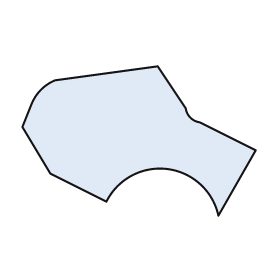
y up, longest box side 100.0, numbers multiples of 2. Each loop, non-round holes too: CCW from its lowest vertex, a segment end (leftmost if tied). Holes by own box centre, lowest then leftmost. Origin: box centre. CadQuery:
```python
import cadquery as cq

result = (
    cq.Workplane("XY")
    .moveTo(34.0, -32.0)
    .lineTo(50.0, -4.0)
    .lineTo(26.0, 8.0)
    .threePointArc((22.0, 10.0), (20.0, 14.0))
    .lineTo(8.0, 32.0)
    .lineTo(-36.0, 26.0)
    .threePointArc((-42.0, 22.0), (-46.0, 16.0))
    .lineTo(-50.0, 6.0)
    .lineTo(-38.0, -14.0)
    .lineTo(-14.0, -26.0)
    .threePointArc((12.0, -12.0), (34.0, -32.0))
    .close()
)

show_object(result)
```